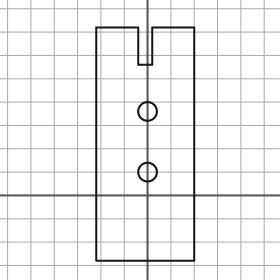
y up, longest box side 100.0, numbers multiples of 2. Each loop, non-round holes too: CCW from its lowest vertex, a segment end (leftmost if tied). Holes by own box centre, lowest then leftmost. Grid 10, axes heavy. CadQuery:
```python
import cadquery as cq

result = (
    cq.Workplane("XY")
    .moveTo(-22.0, -28.0)
    .lineTo(20.0, -28.0)
    .lineTo(20.0, 72.0)
    .lineTo(2.0, 72.0)
    .lineTo(2.0, 56.0)
    .lineTo(-4.0, 56.0)
    .lineTo(-4.0, 72.0)
    .lineTo(-22.0, 72.0)
    .close()
    .moveTo(0.0, 10.0)
    .circle(4.0)
    .moveTo(0.0, 36.0)
    .circle(4.0)
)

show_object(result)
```